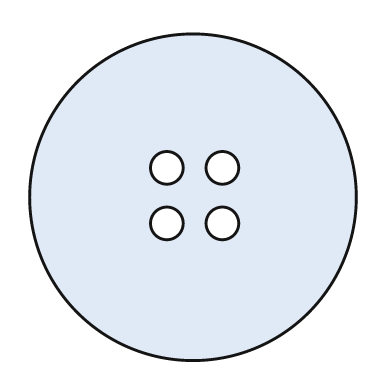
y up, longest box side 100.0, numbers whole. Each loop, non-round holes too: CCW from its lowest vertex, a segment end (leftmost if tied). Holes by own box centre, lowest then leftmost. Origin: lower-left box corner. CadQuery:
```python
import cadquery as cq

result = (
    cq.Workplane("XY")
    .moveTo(50.0, 50.0)
    .circle(50.0)
    .moveTo(42.0, 42.0)
    .circle(5.0)
    .moveTo(59.0, 42.0)
    .circle(5.0)
    .moveTo(42.0, 59.0)
    .circle(5.0)
    .moveTo(59.0, 59.0)
    .circle(5.0)
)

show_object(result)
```